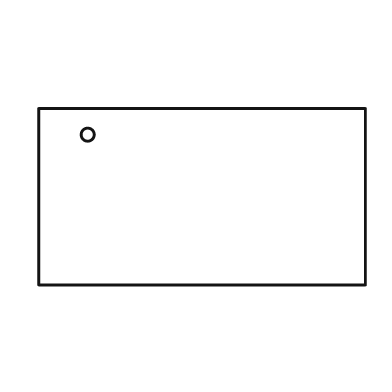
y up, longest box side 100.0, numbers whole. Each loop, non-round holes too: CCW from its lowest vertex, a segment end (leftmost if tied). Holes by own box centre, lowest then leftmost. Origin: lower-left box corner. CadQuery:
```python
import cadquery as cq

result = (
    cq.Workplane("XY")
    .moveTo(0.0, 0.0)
    .lineTo(100.0, 0.0)
    .lineTo(100.0, 54.0)
    .lineTo(0.0, 54.0)
    .close()
    .moveTo(15.0, 46.0)
    .circle(2.0)
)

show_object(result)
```